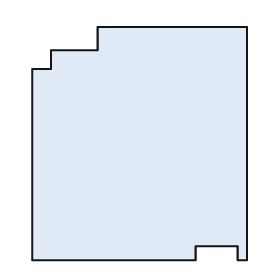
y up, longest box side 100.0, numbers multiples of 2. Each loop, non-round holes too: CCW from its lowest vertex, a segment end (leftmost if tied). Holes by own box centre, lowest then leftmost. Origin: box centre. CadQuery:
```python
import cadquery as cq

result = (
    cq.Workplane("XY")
    .moveTo(-46.0, -50.0)
    .lineTo(24.0, -50.0)
    .lineTo(24.0, -44.0)
    .lineTo(42.0, -44.0)
    .lineTo(42.0, -50.0)
    .lineTo(46.0, -50.0)
    .lineTo(46.0, 50.0)
    .lineTo(-18.0, 50.0)
    .lineTo(-18.0, 40.0)
    .lineTo(-38.0, 40.0)
    .lineTo(-38.0, 32.0)
    .lineTo(-46.0, 32.0)
    .close()
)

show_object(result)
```